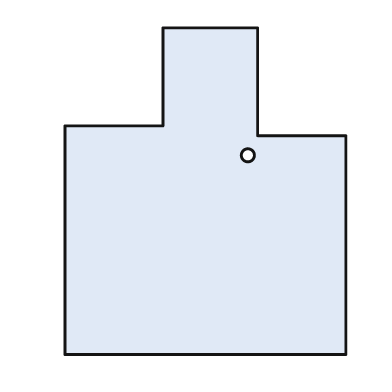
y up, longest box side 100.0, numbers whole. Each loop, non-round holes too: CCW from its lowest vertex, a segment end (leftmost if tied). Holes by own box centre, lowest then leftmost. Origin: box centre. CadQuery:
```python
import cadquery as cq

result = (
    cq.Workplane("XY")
    .moveTo(-43.0, -50.0)
    .lineTo(43.0, -50.0)
    .lineTo(43.0, 17.0)
    .lineTo(16.0, 17.0)
    .lineTo(16.0, 50.0)
    .lineTo(-13.0, 50.0)
    .lineTo(-13.0, 20.0)
    .lineTo(-43.0, 20.0)
    .close()
    .moveTo(13.0, 11.0)
    .circle(2.0)
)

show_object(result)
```